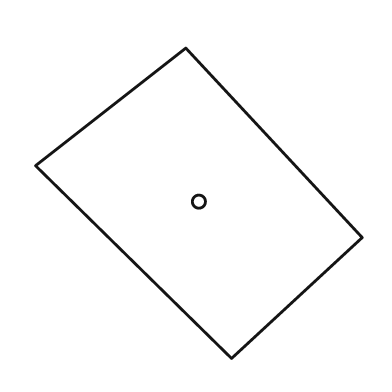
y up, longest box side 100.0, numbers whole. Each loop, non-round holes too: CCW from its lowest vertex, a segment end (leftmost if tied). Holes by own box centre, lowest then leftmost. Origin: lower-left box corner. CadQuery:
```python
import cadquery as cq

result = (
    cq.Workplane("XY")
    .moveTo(60.0, 0.0)
    .lineTo(100.0, 37.0)
    .lineTo(46.0, 95.0)
    .lineTo(0.0, 59.0)
    .close()
    .moveTo(50.0, 48.0)
    .circle(2.0)
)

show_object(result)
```